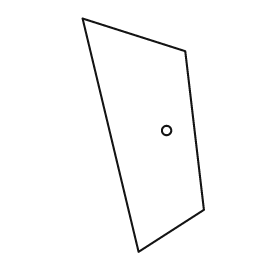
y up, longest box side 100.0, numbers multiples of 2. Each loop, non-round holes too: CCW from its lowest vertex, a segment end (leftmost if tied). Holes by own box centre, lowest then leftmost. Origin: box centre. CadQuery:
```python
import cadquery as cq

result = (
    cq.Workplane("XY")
    .moveTo(-2.0, -50.0)
    .lineTo(26.0, -32.0)
    .lineTo(18.0, 36.0)
    .lineTo(-26.0, 50.0)
    .close()
    .moveTo(10.0, 2.0)
    .circle(2.0)
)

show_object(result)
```